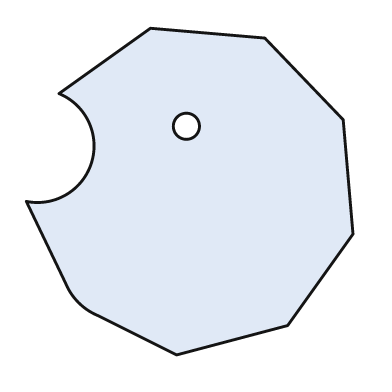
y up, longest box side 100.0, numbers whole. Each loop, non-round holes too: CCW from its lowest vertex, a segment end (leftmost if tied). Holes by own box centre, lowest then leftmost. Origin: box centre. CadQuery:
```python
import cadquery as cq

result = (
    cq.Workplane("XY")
    .moveTo(-4.0, -50.0)
    .lineTo(30.0, -41.0)
    .lineTo(50.0, -13.0)
    .lineTo(47.0, 22.0)
    .lineTo(23.0, 47.0)
    .lineTo(-12.0, 50.0)
    .lineTo(-40.0, 30.0)
    .threePointArc((-30.0, 9.0), (-50.0, -3.0))
    .lineTo(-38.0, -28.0)
    .threePointArc((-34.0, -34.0), (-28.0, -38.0))
    .close()
    .moveTo(-1.0, 20.0)
    .circle(4.0)
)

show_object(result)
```